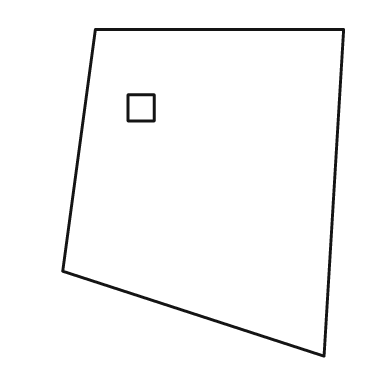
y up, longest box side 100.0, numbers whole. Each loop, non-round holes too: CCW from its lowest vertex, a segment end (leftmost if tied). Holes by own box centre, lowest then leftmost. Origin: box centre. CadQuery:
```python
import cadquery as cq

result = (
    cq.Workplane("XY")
    .moveTo(37.0, -50.0)
    .lineTo(43.0, 50.0)
    .lineTo(-33.0, 50.0)
    .lineTo(-43.0, -24.0)
    .close()
    .moveTo(-23.0, 22.0)
    .lineTo(-15.0, 22.0)
    .lineTo(-15.0, 30.0)
    .lineTo(-23.0, 30.0)
    .close()
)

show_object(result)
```